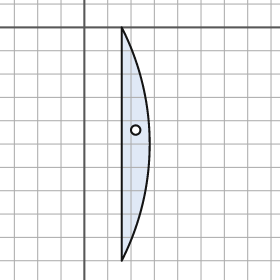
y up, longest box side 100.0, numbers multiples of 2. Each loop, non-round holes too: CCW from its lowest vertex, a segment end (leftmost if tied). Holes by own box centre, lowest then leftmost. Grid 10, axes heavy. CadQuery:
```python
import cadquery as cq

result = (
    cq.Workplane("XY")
    .moveTo(16.0, -100.0)
    .threePointArc((28.0, -50.0), (16.0, 0.0))
    .close()
    .moveTo(22.0, -44.0)
    .circle(2.0)
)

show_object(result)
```